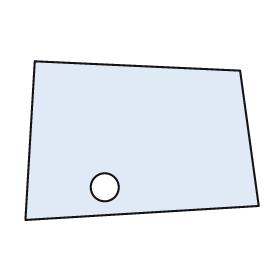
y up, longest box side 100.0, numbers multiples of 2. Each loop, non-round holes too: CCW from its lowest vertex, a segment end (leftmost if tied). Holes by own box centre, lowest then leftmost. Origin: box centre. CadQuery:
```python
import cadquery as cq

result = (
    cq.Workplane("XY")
    .moveTo(-50.0, -34.0)
    .lineTo(50.0, -28.0)
    .lineTo(42.0, 30.0)
    .lineTo(-46.0, 34.0)
    .close()
    .moveTo(-16.0, -20.0)
    .circle(6.0)
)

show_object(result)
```